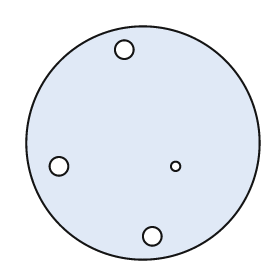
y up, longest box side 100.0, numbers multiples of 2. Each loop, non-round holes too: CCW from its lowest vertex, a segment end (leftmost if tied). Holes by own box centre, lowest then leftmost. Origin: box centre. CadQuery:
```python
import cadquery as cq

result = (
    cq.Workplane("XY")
    .moveTo(0.0, 0.0)
    .circle(50.0)
    .moveTo(4.0, -40.0)
    .circle(4.0)
    .moveTo(-36.0, -10.0)
    .circle(4.0)
    .moveTo(14.0, -10.0)
    .circle(2.0)
    .moveTo(-8.0, 40.0)
    .circle(4.0)
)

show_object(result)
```